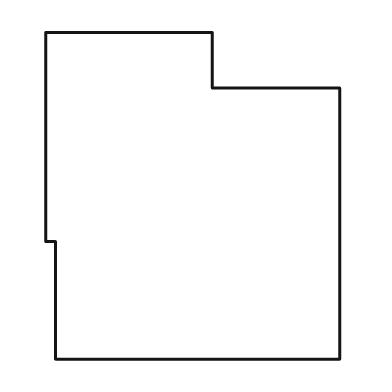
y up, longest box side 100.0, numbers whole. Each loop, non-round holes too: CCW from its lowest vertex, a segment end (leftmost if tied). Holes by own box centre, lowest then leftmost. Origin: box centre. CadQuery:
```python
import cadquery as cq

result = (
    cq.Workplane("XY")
    .moveTo(-42.0, -50.0)
    .lineTo(45.0, -50.0)
    .lineTo(45.0, 33.0)
    .lineTo(6.0, 33.0)
    .lineTo(6.0, 50.0)
    .lineTo(-45.0, 50.0)
    .lineTo(-45.0, -14.0)
    .lineTo(-42.0, -14.0)
    .close()
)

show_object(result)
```